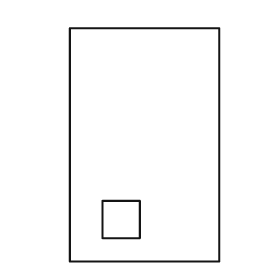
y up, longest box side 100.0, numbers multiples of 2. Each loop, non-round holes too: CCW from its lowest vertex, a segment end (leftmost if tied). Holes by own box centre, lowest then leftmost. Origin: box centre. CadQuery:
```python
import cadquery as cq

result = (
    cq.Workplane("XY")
    .moveTo(-32.0, -50.0)
    .lineTo(32.0, -50.0)
    .lineTo(32.0, 50.0)
    .lineTo(-32.0, 50.0)
    .close()
    .moveTo(-18.0, -40.0)
    .lineTo(-2.0, -40.0)
    .lineTo(-2.0, -24.0)
    .lineTo(-18.0, -24.0)
    .close()
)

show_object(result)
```